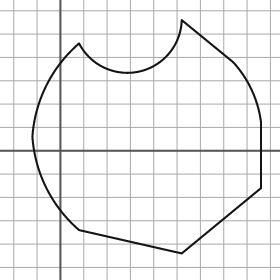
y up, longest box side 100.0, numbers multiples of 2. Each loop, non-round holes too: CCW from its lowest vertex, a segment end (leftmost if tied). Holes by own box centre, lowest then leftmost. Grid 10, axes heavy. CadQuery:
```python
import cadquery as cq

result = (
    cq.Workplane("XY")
    .moveTo(52.0, -44.0)
    .lineTo(86.0, -16.0)
    .lineTo(86.0, 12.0)
    .threePointArc((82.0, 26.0), (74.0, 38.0))
    .lineTo(52.0, 56.0)
    .threePointArc((34.0, 34.0), (8.0, 46.0))
    .threePointArc((-6.0, 28.0), (-12.0, 6.0))
    .threePointArc((-6.0, -16.0), (8.0, -34.0))
    .close()
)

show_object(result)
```